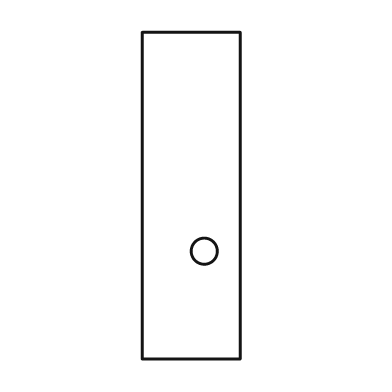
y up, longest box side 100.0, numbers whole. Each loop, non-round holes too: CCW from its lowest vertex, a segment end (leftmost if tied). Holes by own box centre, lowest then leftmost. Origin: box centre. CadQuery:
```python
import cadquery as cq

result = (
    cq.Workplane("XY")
    .moveTo(-15.0, -50.0)
    .lineTo(15.0, -50.0)
    .lineTo(15.0, 50.0)
    .lineTo(-15.0, 50.0)
    .close()
    .moveTo(4.0, -17.0)
    .circle(4.0)
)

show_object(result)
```